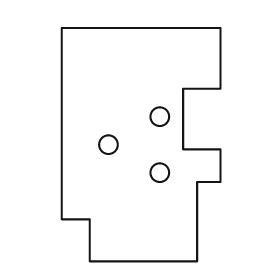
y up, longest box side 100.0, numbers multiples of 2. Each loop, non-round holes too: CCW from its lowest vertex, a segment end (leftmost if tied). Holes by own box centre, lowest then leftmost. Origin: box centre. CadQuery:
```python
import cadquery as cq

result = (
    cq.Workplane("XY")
    .moveTo(-22.0, -50.0)
    .lineTo(24.0, -50.0)
    .lineTo(24.0, -16.0)
    .lineTo(34.0, -16.0)
    .lineTo(34.0, -2.0)
    .lineTo(18.0, -2.0)
    .lineTo(18.0, 24.0)
    .lineTo(34.0, 24.0)
    .lineTo(34.0, 50.0)
    .lineTo(-34.0, 50.0)
    .lineTo(-34.0, -32.0)
    .lineTo(-22.0, -32.0)
    .close()
    .moveTo(8.0, -12.0)
    .circle(4.0)
    .moveTo(-14.0, 0.0)
    .circle(4.0)
    .moveTo(8.0, 12.0)
    .circle(4.0)
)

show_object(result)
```